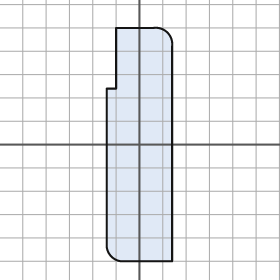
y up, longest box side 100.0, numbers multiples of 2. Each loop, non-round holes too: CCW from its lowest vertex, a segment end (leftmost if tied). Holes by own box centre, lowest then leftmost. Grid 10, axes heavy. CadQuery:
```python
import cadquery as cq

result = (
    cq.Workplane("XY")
    .moveTo(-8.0, -50.0)
    .lineTo(14.0, -50.0)
    .lineTo(14.0, 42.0)
    .threePointArc((12.0, 48.0), (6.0, 50.0))
    .lineTo(-10.0, 50.0)
    .lineTo(-10.0, 24.0)
    .lineTo(-14.0, 24.0)
    .lineTo(-14.0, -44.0)
    .threePointArc((-12.0, -48.0), (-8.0, -50.0))
    .close()
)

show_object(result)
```